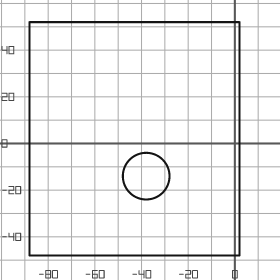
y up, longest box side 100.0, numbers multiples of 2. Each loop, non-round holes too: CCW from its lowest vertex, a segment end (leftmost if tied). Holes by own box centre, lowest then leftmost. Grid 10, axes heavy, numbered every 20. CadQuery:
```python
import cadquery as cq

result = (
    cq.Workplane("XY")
    .moveTo(-88.0, -48.0)
    .lineTo(2.0, -48.0)
    .lineTo(2.0, 52.0)
    .lineTo(-88.0, 52.0)
    .close()
    .moveTo(-38.0, -14.0)
    .circle(10.0)
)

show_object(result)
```